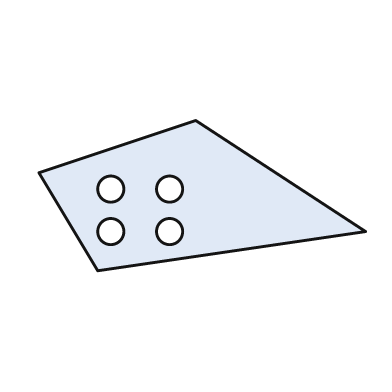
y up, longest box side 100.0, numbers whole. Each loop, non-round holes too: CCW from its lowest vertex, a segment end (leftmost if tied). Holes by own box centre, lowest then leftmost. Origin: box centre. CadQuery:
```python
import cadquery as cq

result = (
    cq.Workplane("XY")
    .moveTo(-32.0, -23.0)
    .lineTo(50.0, -11.0)
    .lineTo(-2.0, 23.0)
    .lineTo(-50.0, 7.0)
    .close()
    .moveTo(-28.0, -11.0)
    .circle(4.0)
    .moveTo(-10.0, -11.0)
    .circle(4.0)
    .moveTo(-28.0, 2.0)
    .circle(4.0)
    .moveTo(-10.0, 2.0)
    .circle(4.0)
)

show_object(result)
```